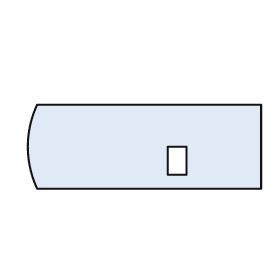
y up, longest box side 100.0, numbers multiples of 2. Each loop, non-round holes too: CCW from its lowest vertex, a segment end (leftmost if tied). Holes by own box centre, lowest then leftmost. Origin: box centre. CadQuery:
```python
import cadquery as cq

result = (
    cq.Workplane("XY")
    .moveTo(-46.0, -18.0)
    .lineTo(50.0, -18.0)
    .lineTo(50.0, 18.0)
    .lineTo(-46.0, 18.0)
    .threePointArc((-50.0, 0.0), (-46.0, -18.0))
    .close()
    .moveTo(10.0, -12.0)
    .lineTo(18.0, -12.0)
    .lineTo(18.0, 0.0)
    .lineTo(10.0, 0.0)
    .close()
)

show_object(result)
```